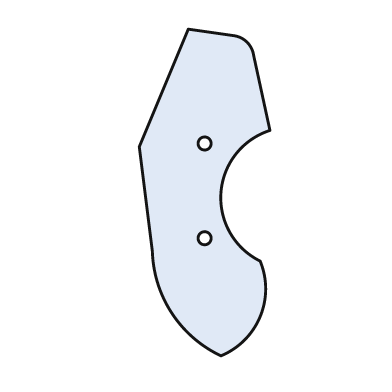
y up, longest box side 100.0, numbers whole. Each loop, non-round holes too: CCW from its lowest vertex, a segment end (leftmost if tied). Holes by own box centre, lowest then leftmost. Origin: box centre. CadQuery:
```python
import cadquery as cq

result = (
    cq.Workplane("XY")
    .moveTo(5.0, -50.0)
    .threePointArc((17.0, -38.0), (17.0, -21.0))
    .threePointArc((5.0, 0.0), (20.0, 19.0))
    .lineTo(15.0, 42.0)
    .threePointArc((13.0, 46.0), (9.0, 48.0))
    .lineTo(-5.0, 50.0)
    .lineTo(-20.0, 14.0)
    .lineTo(-16.0, -18.0)
    .threePointArc((-10.0, -37.0), (5.0, -50.0))
    .close()
    .moveTo(0.0, -14.0)
    .circle(2.0)
    .moveTo(0.0, 15.0)
    .circle(2.0)
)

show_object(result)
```